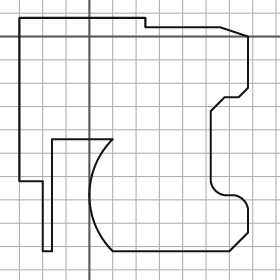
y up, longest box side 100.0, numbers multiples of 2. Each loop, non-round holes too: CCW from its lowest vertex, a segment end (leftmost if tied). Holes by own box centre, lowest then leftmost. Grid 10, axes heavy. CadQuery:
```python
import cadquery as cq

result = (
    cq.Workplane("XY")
    .moveTo(-20.0, -92.0)
    .lineTo(-16.0, -92.0)
    .lineTo(-16.0, -44.0)
    .lineTo(10.0, -44.0)
    .threePointArc((0.0, -68.0), (10.0, -92.0))
    .lineTo(60.0, -92.0)
    .lineTo(68.0, -84.0)
    .lineTo(68.0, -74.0)
    .threePointArc((66.0, -70.0), (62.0, -68.0))
    .lineTo(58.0, -68.0)
    .threePointArc((54.0, -66.0), (52.0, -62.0))
    .lineTo(52.0, -32.0)
    .lineTo(58.0, -26.0)
    .lineTo(64.0, -26.0)
    .lineTo(68.0, -22.0)
    .lineTo(68.0, 0.0)
    .lineTo(56.0, 4.0)
    .lineTo(24.0, 4.0)
    .lineTo(24.0, 8.0)
    .lineTo(-30.0, 8.0)
    .lineTo(-30.0, -62.0)
    .lineTo(-20.0, -62.0)
    .close()
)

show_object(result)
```